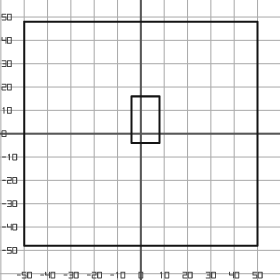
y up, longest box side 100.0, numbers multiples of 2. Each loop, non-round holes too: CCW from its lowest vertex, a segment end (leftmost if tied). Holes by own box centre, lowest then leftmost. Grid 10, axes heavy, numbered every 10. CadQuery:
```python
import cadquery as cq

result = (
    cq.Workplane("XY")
    .moveTo(-50.0, -48.0)
    .lineTo(50.0, -48.0)
    .lineTo(50.0, 48.0)
    .lineTo(-50.0, 48.0)
    .close()
    .moveTo(-4.0, -4.0)
    .lineTo(8.0, -4.0)
    .lineTo(8.0, 16.0)
    .lineTo(-4.0, 16.0)
    .close()
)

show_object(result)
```